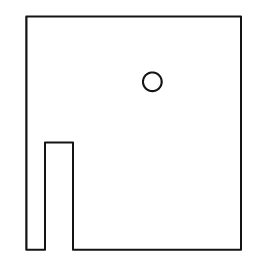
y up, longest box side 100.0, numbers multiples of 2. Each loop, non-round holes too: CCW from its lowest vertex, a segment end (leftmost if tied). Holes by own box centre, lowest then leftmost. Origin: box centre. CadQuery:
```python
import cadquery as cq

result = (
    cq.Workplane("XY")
    .moveTo(-46.0, -50.0)
    .lineTo(-38.0, -50.0)
    .lineTo(-38.0, -4.0)
    .lineTo(-26.0, -4.0)
    .lineTo(-26.0, -50.0)
    .lineTo(46.0, -50.0)
    .lineTo(46.0, 50.0)
    .lineTo(-46.0, 50.0)
    .close()
    .moveTo(8.0, 22.0)
    .circle(4.0)
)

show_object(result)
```